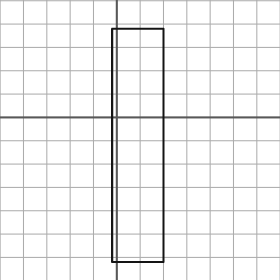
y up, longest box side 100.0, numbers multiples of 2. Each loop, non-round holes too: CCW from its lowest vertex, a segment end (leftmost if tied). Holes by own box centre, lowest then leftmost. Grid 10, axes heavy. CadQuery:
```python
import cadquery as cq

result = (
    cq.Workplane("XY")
    .moveTo(-2.0, -62.0)
    .lineTo(20.0, -62.0)
    .lineTo(20.0, 38.0)
    .lineTo(-2.0, 38.0)
    .close()
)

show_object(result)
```